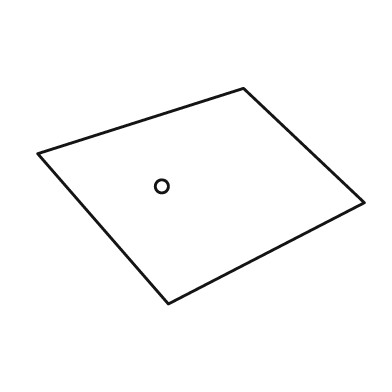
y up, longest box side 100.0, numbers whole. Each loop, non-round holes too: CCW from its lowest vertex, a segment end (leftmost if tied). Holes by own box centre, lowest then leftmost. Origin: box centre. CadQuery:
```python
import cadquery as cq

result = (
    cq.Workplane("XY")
    .moveTo(-10.0, -33.0)
    .lineTo(50.0, -2.0)
    .lineTo(13.0, 33.0)
    .lineTo(-50.0, 13.0)
    .close()
    .moveTo(-12.0, 3.0)
    .circle(2.0)
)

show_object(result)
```